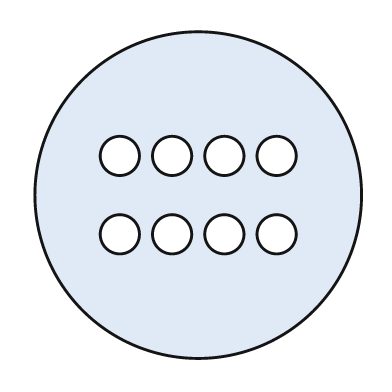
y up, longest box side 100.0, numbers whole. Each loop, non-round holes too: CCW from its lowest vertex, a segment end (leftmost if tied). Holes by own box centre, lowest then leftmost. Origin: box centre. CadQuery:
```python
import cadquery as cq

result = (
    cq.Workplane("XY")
    .moveTo(0.0, 0.0)
    .circle(50.0)
    .moveTo(-24.0, -12.0)
    .circle(6.0)
    .moveTo(-8.0, -12.0)
    .circle(6.0)
    .moveTo(8.0, -12.0)
    .circle(6.0)
    .moveTo(24.0, -12.0)
    .circle(6.0)
    .moveTo(-24.0, 12.0)
    .circle(6.0)
    .moveTo(-8.0, 12.0)
    .circle(6.0)
    .moveTo(8.0, 12.0)
    .circle(6.0)
    .moveTo(24.0, 12.0)
    .circle(6.0)
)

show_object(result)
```